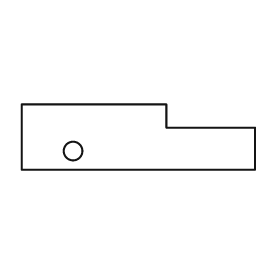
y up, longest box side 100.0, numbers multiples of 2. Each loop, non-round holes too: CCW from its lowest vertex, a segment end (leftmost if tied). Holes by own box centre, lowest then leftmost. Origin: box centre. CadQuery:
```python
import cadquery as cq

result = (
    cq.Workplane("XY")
    .moveTo(-50.0, -14.0)
    .lineTo(50.0, -14.0)
    .lineTo(50.0, 4.0)
    .lineTo(12.0, 4.0)
    .lineTo(12.0, 14.0)
    .lineTo(-50.0, 14.0)
    .close()
    .moveTo(-28.0, -6.0)
    .circle(4.0)
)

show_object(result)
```